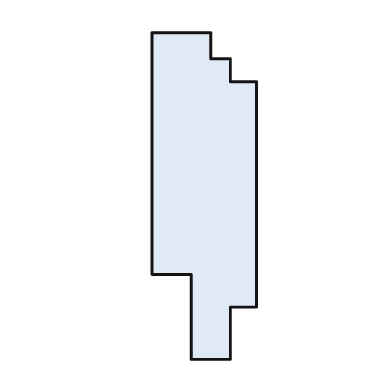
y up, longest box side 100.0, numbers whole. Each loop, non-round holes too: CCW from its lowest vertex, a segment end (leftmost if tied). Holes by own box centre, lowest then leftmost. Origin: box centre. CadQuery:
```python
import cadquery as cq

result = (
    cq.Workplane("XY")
    .moveTo(-4.0, -50.0)
    .lineTo(8.0, -50.0)
    .lineTo(8.0, -34.0)
    .lineTo(16.0, -34.0)
    .lineTo(16.0, 35.0)
    .lineTo(8.0, 35.0)
    .lineTo(8.0, 42.0)
    .lineTo(2.0, 42.0)
    .lineTo(2.0, 50.0)
    .lineTo(-16.0, 50.0)
    .lineTo(-16.0, -24.0)
    .lineTo(-4.0, -24.0)
    .close()
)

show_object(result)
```